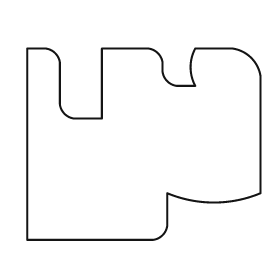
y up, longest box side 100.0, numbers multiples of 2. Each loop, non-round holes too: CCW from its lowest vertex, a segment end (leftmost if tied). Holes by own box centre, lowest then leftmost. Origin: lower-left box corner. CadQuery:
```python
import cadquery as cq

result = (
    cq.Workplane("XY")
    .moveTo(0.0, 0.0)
    .lineTo(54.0, 0.0)
    .threePointArc((58.0, 2.0), (60.0, 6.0))
    .lineTo(60.0, 20.0)
    .threePointArc((80.0, 16.0), (100.0, 20.0))
    .lineTo(100.0, 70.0)
    .threePointArc((96.0, 78.0), (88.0, 82.0))
    .lineTo(72.0, 82.0)
    .threePointArc((70.0, 74.0), (72.0, 66.0))
    .lineTo(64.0, 66.0)
    .threePointArc((60.0, 68.0), (58.0, 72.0))
    .lineTo(58.0, 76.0)
    .threePointArc((56.0, 80.0), (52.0, 82.0))
    .lineTo(32.0, 82.0)
    .lineTo(32.0, 52.0)
    .lineTo(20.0, 52.0)
    .threePointArc((16.0, 54.0), (14.0, 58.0))
    .lineTo(14.0, 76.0)
    .threePointArc((12.0, 80.0), (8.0, 82.0))
    .lineTo(0.0, 82.0)
    .close()
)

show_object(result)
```